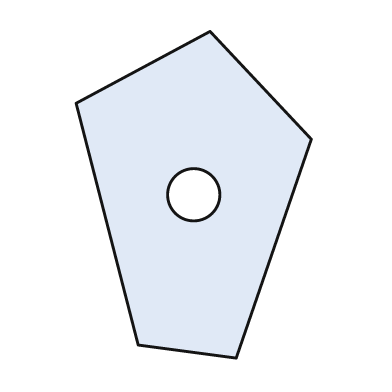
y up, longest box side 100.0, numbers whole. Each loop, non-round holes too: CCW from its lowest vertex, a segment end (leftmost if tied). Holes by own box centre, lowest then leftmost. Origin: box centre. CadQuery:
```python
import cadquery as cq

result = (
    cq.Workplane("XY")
    .moveTo(13.0, -50.0)
    .lineTo(36.0, 17.0)
    .lineTo(5.0, 50.0)
    .lineTo(-36.0, 28.0)
    .lineTo(-17.0, -46.0)
    .close()
    .moveTo(0.0, 0.0)
    .circle(8.0)
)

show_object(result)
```